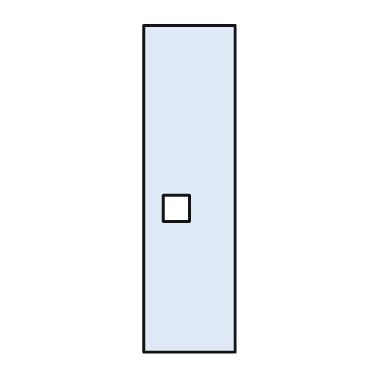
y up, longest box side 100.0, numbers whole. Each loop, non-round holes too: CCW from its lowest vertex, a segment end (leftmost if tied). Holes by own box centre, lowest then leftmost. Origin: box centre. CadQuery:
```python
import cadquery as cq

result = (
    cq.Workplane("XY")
    .moveTo(-14.0, -50.0)
    .lineTo(14.0, -50.0)
    .lineTo(14.0, 50.0)
    .lineTo(-14.0, 50.0)
    .close()
    .moveTo(-8.0, -10.0)
    .lineTo(0.0, -10.0)
    .lineTo(0.0, -2.0)
    .lineTo(-8.0, -2.0)
    .close()
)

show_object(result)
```